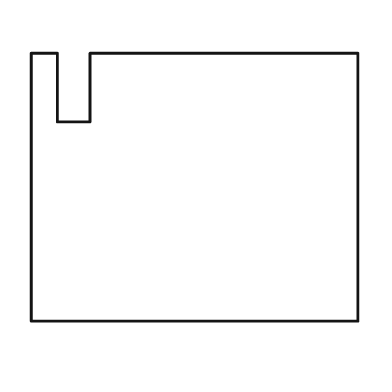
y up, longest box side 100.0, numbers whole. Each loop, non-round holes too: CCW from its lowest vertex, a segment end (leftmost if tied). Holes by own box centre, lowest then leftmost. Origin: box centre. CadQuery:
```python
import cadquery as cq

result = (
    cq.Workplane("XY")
    .moveTo(-50.0, -41.0)
    .lineTo(50.0, -41.0)
    .lineTo(50.0, 41.0)
    .lineTo(-32.0, 41.0)
    .lineTo(-32.0, 20.0)
    .lineTo(-42.0, 20.0)
    .lineTo(-42.0, 41.0)
    .lineTo(-50.0, 41.0)
    .close()
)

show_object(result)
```